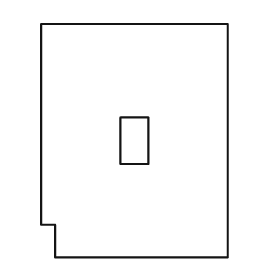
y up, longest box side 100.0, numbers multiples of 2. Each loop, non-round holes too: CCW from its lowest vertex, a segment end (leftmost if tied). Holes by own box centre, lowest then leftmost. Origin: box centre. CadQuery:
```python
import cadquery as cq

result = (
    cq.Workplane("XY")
    .moveTo(-34.0, -50.0)
    .lineTo(40.0, -50.0)
    .lineTo(40.0, 50.0)
    .lineTo(-40.0, 50.0)
    .lineTo(-40.0, -36.0)
    .lineTo(-34.0, -36.0)
    .close()
    .moveTo(-6.0, -10.0)
    .lineTo(6.0, -10.0)
    .lineTo(6.0, 10.0)
    .lineTo(-6.0, 10.0)
    .close()
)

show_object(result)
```